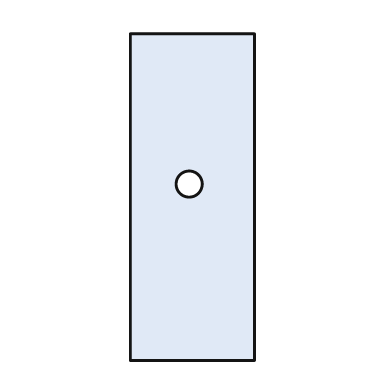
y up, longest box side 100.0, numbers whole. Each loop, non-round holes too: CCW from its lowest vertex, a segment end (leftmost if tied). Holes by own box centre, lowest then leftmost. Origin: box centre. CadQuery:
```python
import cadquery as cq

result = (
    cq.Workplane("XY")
    .moveTo(-19.0, -50.0)
    .lineTo(19.0, -50.0)
    .lineTo(19.0, 50.0)
    .lineTo(-19.0, 50.0)
    .close()
    .moveTo(-1.0, 4.0)
    .circle(4.0)
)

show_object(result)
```